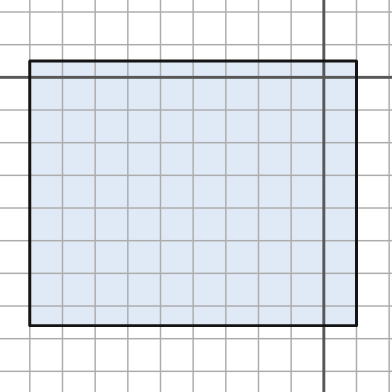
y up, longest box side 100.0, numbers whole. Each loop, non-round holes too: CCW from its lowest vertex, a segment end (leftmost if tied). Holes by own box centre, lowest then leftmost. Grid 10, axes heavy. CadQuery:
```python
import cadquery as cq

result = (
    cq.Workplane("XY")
    .moveTo(-90.0, -76.0)
    .lineTo(10.0, -76.0)
    .lineTo(10.0, 5.0)
    .lineTo(-90.0, 5.0)
    .close()
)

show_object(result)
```